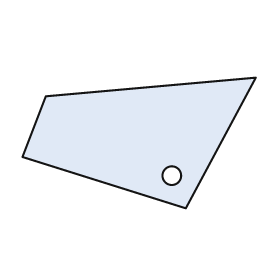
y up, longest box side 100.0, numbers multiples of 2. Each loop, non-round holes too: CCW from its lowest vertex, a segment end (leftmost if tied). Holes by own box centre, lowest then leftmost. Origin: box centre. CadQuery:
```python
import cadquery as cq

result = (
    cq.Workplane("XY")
    .moveTo(20.0, -28.0)
    .lineTo(50.0, 28.0)
    .lineTo(-40.0, 20.0)
    .lineTo(-50.0, -6.0)
    .close()
    .moveTo(14.0, -14.0)
    .circle(4.0)
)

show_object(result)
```